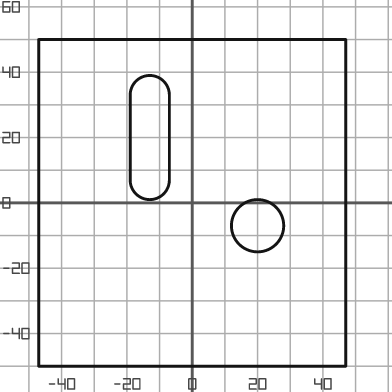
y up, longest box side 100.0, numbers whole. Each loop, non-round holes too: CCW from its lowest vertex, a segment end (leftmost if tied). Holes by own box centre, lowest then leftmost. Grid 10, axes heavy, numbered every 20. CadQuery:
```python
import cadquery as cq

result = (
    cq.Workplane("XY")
    .moveTo(-47.0, -50.0)
    .lineTo(47.0, -50.0)
    .lineTo(47.0, 50.0)
    .lineTo(-47.0, 50.0)
    .close()
    .moveTo(20.0, -7.0)
    .circle(8.0)
    .moveTo(-19.0, 7.0)
    .threePointArc((-13.0, 1.0), (-7.0, 7.0))
    .lineTo(-7.0, 33.0)
    .threePointArc((-13.0, 39.0), (-19.0, 33.0))
    .close()
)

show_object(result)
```